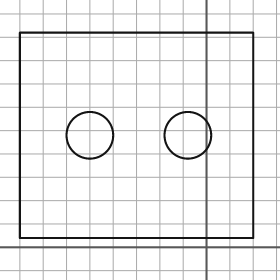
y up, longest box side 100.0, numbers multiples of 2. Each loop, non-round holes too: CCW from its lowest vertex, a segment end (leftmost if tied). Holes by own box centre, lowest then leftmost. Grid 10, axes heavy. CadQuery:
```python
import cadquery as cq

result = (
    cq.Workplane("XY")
    .moveTo(-80.0, 4.0)
    .lineTo(20.0, 4.0)
    .lineTo(20.0, 92.0)
    .lineTo(-80.0, 92.0)
    .close()
    .moveTo(-50.0, 48.0)
    .circle(10.0)
    .moveTo(-8.0, 48.0)
    .circle(10.0)
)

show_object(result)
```